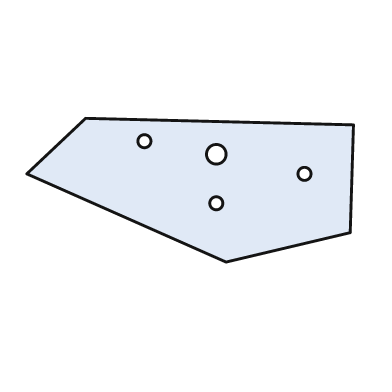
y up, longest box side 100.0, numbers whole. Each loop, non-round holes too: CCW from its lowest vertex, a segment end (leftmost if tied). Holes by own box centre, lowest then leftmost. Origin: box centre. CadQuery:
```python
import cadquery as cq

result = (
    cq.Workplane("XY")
    .moveTo(11.0, -22.0)
    .lineTo(49.0, -13.0)
    .lineTo(50.0, 20.0)
    .lineTo(-32.0, 22.0)
    .lineTo(-50.0, 5.0)
    .close()
    .moveTo(8.0, -4.0)
    .circle(2.0)
    .moveTo(35.0, 5.0)
    .circle(2.0)
    .moveTo(8.0, 11.0)
    .circle(3.0)
    .moveTo(-14.0, 15.0)
    .circle(2.0)
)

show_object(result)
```